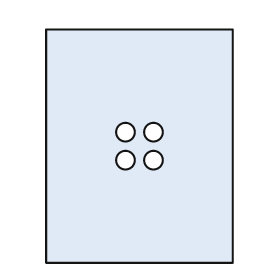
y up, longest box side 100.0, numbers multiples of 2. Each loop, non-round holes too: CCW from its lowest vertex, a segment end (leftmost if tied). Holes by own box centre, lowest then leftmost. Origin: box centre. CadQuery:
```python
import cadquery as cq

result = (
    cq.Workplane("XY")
    .moveTo(-40.0, -50.0)
    .lineTo(40.0, -50.0)
    .lineTo(40.0, 50.0)
    .lineTo(-40.0, 50.0)
    .close()
    .moveTo(-6.0, -6.0)
    .circle(4.0)
    .moveTo(6.0, -6.0)
    .circle(4.0)
    .moveTo(-6.0, 6.0)
    .circle(4.0)
    .moveTo(6.0, 6.0)
    .circle(4.0)
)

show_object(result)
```